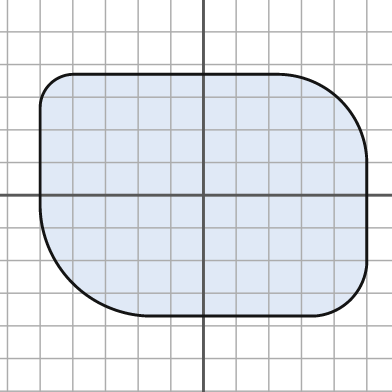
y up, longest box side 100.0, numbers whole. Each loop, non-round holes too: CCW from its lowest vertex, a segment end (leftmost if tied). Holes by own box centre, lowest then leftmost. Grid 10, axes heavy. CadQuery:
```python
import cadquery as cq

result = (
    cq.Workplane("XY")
    .moveTo(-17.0, -37.0)
    .lineTo(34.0, -37.0)
    .threePointArc((45.0, -32.0), (50.0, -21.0))
    .lineTo(50.0, 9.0)
    .threePointArc((42.0, 29.0), (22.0, 37.0))
    .lineTo(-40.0, 37.0)
    .threePointArc((-47.0, 34.0), (-50.0, 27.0))
    .lineTo(-50.0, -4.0)
    .threePointArc((-40.0, -27.0), (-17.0, -37.0))
    .close()
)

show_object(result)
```